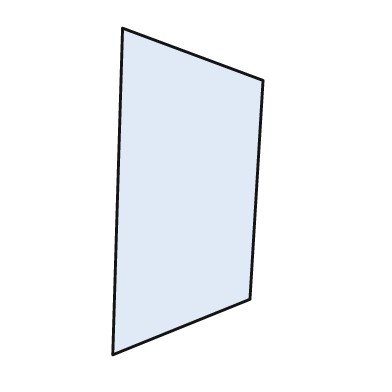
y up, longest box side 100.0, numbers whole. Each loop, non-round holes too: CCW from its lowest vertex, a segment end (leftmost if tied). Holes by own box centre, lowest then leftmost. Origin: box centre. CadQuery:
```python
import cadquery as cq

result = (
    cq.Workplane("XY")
    .moveTo(-23.0, -50.0)
    .lineTo(19.0, -33.0)
    .lineTo(23.0, 34.0)
    .lineTo(-20.0, 50.0)
    .close()
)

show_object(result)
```